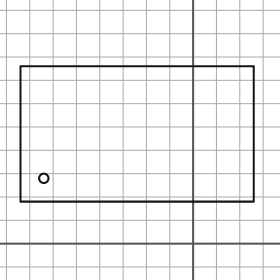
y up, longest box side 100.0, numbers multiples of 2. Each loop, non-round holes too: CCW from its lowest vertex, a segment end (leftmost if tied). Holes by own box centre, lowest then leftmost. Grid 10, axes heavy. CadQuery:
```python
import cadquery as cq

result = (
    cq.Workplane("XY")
    .moveTo(-74.0, 18.0)
    .lineTo(26.0, 18.0)
    .lineTo(26.0, 76.0)
    .lineTo(-74.0, 76.0)
    .close()
    .moveTo(-64.0, 28.0)
    .circle(2.0)
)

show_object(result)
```